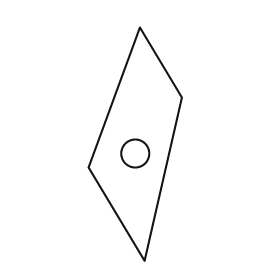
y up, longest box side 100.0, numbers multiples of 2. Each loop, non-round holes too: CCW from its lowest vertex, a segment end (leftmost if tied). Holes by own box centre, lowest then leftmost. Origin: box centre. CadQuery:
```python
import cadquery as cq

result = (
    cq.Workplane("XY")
    .moveTo(4.0, -50.0)
    .lineTo(20.0, 20.0)
    .lineTo(2.0, 50.0)
    .lineTo(-20.0, -10.0)
    .close()
    .moveTo(0.0, -4.0)
    .circle(6.0)
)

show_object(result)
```